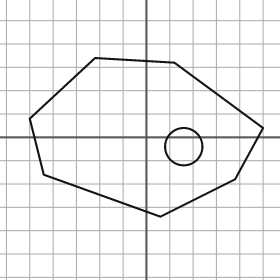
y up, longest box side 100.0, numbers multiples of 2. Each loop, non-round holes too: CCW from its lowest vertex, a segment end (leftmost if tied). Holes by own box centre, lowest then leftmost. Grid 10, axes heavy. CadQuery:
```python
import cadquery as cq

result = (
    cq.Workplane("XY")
    .moveTo(6.0, -34.0)
    .lineTo(38.0, -18.0)
    .lineTo(50.0, 4.0)
    .lineTo(12.0, 32.0)
    .lineTo(-22.0, 34.0)
    .lineTo(-50.0, 8.0)
    .lineTo(-44.0, -16.0)
    .close()
    .moveTo(16.0, -4.0)
    .circle(8.0)
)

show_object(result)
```